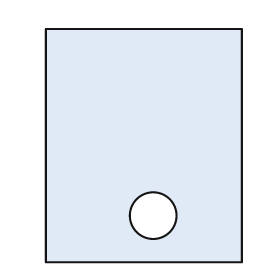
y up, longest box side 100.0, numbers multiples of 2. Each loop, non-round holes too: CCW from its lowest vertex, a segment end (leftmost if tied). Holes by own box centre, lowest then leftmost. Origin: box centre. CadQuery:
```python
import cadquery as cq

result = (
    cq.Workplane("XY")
    .moveTo(-42.0, -50.0)
    .lineTo(42.0, -50.0)
    .lineTo(42.0, 50.0)
    .lineTo(-42.0, 50.0)
    .close()
    .moveTo(4.0, -30.0)
    .circle(10.0)
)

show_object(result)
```